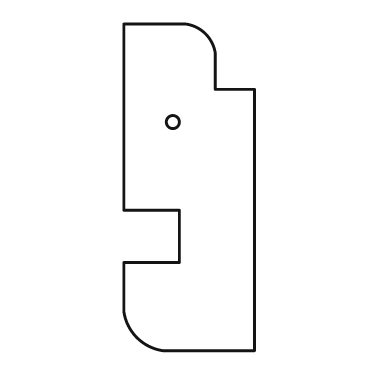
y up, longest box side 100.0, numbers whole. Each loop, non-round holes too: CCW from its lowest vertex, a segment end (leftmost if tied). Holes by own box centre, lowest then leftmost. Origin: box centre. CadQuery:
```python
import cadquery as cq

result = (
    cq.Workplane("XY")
    .moveTo(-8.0, -50.0)
    .lineTo(20.0, -50.0)
    .lineTo(20.0, 30.0)
    .lineTo(8.0, 30.0)
    .lineTo(8.0, 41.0)
    .threePointArc((5.0, 47.0), (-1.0, 50.0))
    .lineTo(-20.0, 50.0)
    .lineTo(-20.0, -7.0)
    .lineTo(-3.0, -7.0)
    .lineTo(-3.0, -23.0)
    .lineTo(-20.0, -23.0)
    .lineTo(-20.0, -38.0)
    .threePointArc((-16.0, -46.0), (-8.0, -50.0))
    .close()
    .moveTo(-5.0, 20.0)
    .circle(2.0)
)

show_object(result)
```